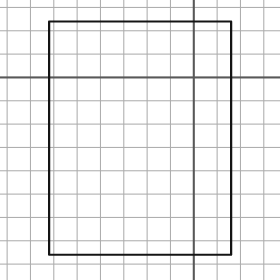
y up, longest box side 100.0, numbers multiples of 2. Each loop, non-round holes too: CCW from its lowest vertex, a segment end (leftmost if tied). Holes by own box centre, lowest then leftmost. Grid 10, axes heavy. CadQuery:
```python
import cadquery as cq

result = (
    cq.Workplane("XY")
    .moveTo(-62.0, -76.0)
    .lineTo(16.0, -76.0)
    .lineTo(16.0, 24.0)
    .lineTo(-62.0, 24.0)
    .close()
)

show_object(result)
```